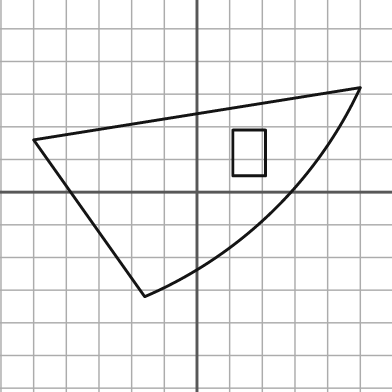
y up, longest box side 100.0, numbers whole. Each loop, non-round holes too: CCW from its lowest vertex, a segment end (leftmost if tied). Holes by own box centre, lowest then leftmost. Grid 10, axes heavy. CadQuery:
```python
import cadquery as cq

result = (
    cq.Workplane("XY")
    .moveTo(-16.0, -32.0)
    .threePointArc((23.0, -6.0), (50.0, 32.0))
    .lineTo(-50.0, 16.0)
    .close()
    .moveTo(11.0, 5.0)
    .lineTo(21.0, 5.0)
    .lineTo(21.0, 19.0)
    .lineTo(11.0, 19.0)
    .close()
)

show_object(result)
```